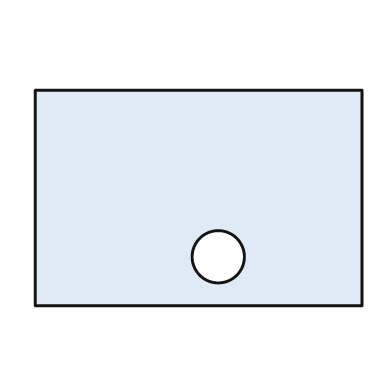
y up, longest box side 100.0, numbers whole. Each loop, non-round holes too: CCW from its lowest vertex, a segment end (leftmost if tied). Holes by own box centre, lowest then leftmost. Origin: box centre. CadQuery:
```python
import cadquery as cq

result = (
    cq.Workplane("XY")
    .moveTo(-50.0, -33.0)
    .lineTo(50.0, -33.0)
    .lineTo(50.0, 33.0)
    .lineTo(-50.0, 33.0)
    .close()
    .moveTo(6.0, -18.0)
    .circle(8.0)
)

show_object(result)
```